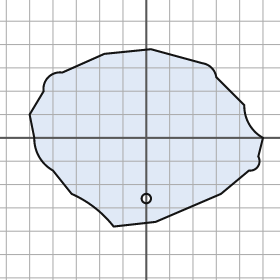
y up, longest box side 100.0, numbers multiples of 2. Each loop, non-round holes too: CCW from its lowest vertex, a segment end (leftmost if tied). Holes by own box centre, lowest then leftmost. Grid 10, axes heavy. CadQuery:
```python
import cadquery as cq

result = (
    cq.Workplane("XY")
    .moveTo(-14.0, -38.0)
    .lineTo(4.0, -36.0)
    .lineTo(32.0, -24.0)
    .lineTo(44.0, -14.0)
    .threePointArc((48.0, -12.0), (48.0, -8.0))
    .lineTo(50.0, 0.0)
    .threePointArc((44.0, 6.0), (42.0, 14.0))
    .lineTo(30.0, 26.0)
    .threePointArc((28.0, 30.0), (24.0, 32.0))
    .lineTo(2.0, 38.0)
    .lineTo(-18.0, 36.0)
    .lineTo(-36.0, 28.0)
    .threePointArc((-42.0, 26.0), (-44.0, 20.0))
    .lineTo(-50.0, 10.0)
    .lineTo(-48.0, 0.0)
    .threePointArc((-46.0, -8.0), (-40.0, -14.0))
    .lineTo(-32.0, -24.0)
    .threePointArc((-22.0, -30.0), (-14.0, -38.0))
    .close()
    .moveTo(0.0, -26.0)
    .circle(2.0)
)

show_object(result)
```